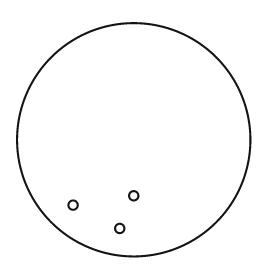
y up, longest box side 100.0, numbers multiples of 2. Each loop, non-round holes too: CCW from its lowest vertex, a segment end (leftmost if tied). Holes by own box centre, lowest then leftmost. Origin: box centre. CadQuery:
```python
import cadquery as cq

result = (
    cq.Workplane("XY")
    .moveTo(0.0, 0.0)
    .circle(50.0)
    .moveTo(-6.0, -38.0)
    .circle(2.0)
    .moveTo(-26.0, -28.0)
    .circle(2.0)
    .moveTo(0.0, -24.0)
    .circle(2.0)
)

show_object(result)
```